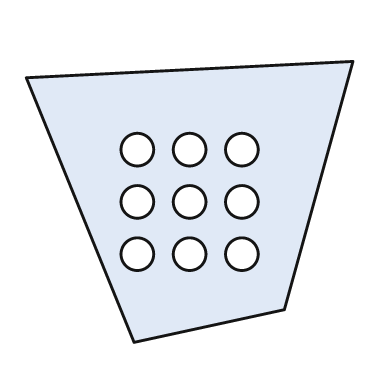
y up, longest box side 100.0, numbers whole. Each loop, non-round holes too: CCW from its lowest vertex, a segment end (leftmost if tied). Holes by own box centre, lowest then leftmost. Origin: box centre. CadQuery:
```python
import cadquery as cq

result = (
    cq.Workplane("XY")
    .moveTo(-17.0, -43.0)
    .lineTo(29.0, -33.0)
    .lineTo(50.0, 43.0)
    .lineTo(-50.0, 38.0)
    .close()
    .moveTo(-16.0, -16.0)
    .circle(5.0)
    .moveTo(0.0, -16.0)
    .circle(5.0)
    .moveTo(16.0, -16.0)
    .circle(5.0)
    .moveTo(-16.0, 0.0)
    .circle(5.0)
    .moveTo(0.0, 0.0)
    .circle(5.0)
    .moveTo(16.0, 0.0)
    .circle(5.0)
    .moveTo(-16.0, 16.0)
    .circle(5.0)
    .moveTo(0.0, 16.0)
    .circle(5.0)
    .moveTo(16.0, 16.0)
    .circle(5.0)
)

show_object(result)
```